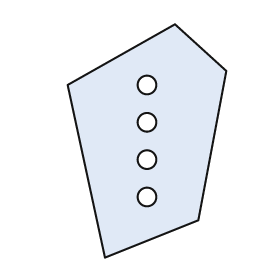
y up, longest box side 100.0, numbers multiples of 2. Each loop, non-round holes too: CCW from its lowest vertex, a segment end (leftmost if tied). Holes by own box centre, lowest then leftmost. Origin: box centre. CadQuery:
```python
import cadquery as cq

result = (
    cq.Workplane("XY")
    .moveTo(-18.0, -50.0)
    .lineTo(22.0, -34.0)
    .lineTo(34.0, 30.0)
    .lineTo(12.0, 50.0)
    .lineTo(-34.0, 24.0)
    .close()
    .moveTo(0.0, -24.0)
    .circle(4.0)
    .moveTo(0.0, -8.0)
    .circle(4.0)
    .moveTo(0.0, 8.0)
    .circle(4.0)
    .moveTo(0.0, 24.0)
    .circle(4.0)
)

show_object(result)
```